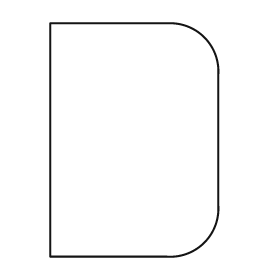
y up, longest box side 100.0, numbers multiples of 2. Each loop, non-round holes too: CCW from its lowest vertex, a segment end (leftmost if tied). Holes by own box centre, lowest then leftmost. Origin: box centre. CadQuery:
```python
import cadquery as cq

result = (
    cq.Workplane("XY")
    .moveTo(-36.0, -50.0)
    .lineTo(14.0, -50.0)
    .threePointArc((30.0, -44.0), (36.0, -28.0))
    .lineTo(36.0, 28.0)
    .threePointArc((30.0, 44.0), (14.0, 50.0))
    .lineTo(-36.0, 50.0)
    .close()
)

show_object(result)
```